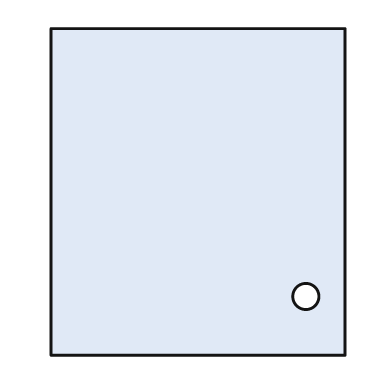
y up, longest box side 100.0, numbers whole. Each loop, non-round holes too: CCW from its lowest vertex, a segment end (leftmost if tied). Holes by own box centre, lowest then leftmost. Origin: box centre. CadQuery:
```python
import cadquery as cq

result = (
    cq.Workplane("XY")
    .moveTo(-45.0, -50.0)
    .lineTo(45.0, -50.0)
    .lineTo(45.0, 50.0)
    .lineTo(-45.0, 50.0)
    .close()
    .moveTo(33.0, -32.0)
    .circle(4.0)
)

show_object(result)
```